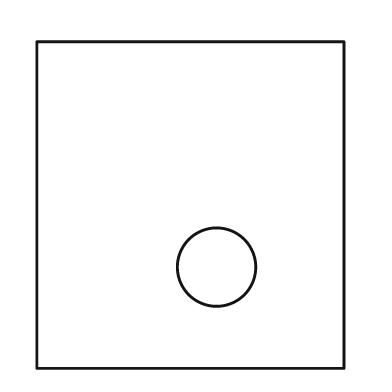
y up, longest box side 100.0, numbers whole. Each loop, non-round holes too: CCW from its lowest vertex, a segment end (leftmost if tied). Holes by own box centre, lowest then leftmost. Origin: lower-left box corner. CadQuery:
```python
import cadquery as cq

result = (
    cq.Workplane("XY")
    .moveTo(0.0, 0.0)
    .lineTo(94.0, 0.0)
    .lineTo(94.0, 100.0)
    .lineTo(0.0, 100.0)
    .close()
    .moveTo(55.0, 31.0)
    .circle(12.0)
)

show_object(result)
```